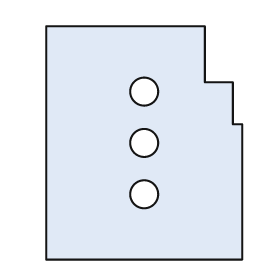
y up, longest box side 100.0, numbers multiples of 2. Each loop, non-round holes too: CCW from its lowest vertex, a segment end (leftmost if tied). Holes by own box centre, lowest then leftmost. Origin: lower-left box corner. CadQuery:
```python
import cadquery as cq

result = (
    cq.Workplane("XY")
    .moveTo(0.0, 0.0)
    .lineTo(84.0, 0.0)
    .lineTo(84.0, 58.0)
    .lineTo(80.0, 58.0)
    .lineTo(80.0, 76.0)
    .lineTo(68.0, 76.0)
    .lineTo(68.0, 100.0)
    .lineTo(0.0, 100.0)
    .close()
    .moveTo(42.0, 28.0)
    .circle(6.0)
    .moveTo(42.0, 50.0)
    .circle(6.0)
    .moveTo(42.0, 72.0)
    .circle(6.0)
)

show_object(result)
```